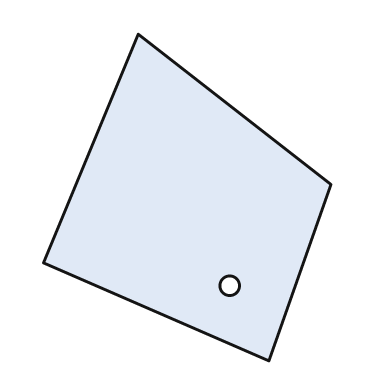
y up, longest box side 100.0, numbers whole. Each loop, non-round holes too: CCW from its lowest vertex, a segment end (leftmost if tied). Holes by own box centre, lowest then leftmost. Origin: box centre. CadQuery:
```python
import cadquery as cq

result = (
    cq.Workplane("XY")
    .moveTo(25.0, -50.0)
    .lineTo(44.0, 4.0)
    .lineTo(-15.0, 50.0)
    .lineTo(-44.0, -20.0)
    .close()
    .moveTo(13.0, -27.0)
    .circle(3.0)
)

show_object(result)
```